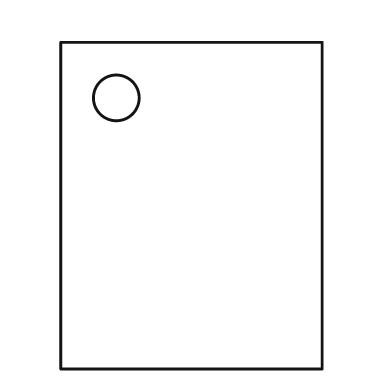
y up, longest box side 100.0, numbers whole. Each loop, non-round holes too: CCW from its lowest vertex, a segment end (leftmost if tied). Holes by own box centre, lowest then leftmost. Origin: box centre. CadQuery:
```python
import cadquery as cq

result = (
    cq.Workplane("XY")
    .moveTo(-40.0, -50.0)
    .lineTo(40.0, -50.0)
    .lineTo(40.0, 50.0)
    .lineTo(-40.0, 50.0)
    .close()
    .moveTo(-23.0, 33.0)
    .circle(7.0)
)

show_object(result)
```